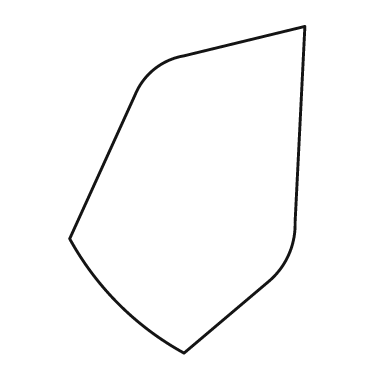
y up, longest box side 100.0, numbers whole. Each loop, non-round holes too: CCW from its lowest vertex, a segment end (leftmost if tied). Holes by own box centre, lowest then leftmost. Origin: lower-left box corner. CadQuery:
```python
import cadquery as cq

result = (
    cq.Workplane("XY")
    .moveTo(35.0, 0.0)
    .lineTo(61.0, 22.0)
    .threePointArc((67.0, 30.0), (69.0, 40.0))
    .lineTo(72.0, 100.0)
    .lineTo(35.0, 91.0)
    .threePointArc((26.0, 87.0), (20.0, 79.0))
    .lineTo(0.0, 35.0)
    .threePointArc((15.0, 15.0), (35.0, 0.0))
    .close()
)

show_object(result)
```